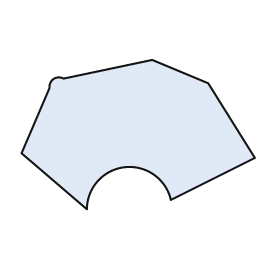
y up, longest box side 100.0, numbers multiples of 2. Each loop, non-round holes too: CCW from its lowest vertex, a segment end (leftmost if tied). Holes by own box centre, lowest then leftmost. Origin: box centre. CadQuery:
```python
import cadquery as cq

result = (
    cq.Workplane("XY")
    .moveTo(-22.0, -32.0)
    .threePointArc((-6.0, -14.0), (14.0, -28.0))
    .lineTo(50.0, -10.0)
    .lineTo(30.0, 22.0)
    .lineTo(6.0, 32.0)
    .lineTo(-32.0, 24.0)
    .threePointArc((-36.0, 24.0), (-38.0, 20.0))
    .lineTo(-50.0, -8.0)
    .close()
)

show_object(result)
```